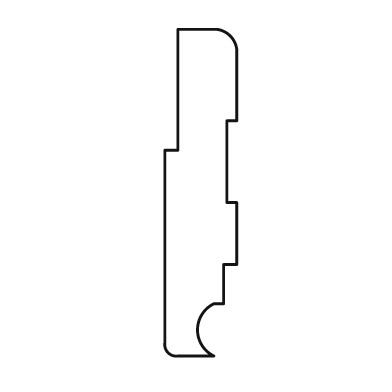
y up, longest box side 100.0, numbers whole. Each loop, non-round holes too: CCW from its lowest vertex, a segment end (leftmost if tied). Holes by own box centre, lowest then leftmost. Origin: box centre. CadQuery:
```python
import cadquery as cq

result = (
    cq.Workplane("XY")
    .moveTo(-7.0, -50.0)
    .lineTo(4.0, -50.0)
    .threePointArc((-1.0, -42.0), (4.0, -34.0))
    .lineTo(7.0, -34.0)
    .lineTo(7.0, -22.0)
    .lineTo(11.0, -22.0)
    .lineTo(11.0, -3.0)
    .lineTo(8.0, -3.0)
    .lineTo(8.0, 22.0)
    .lineTo(11.0, 22.0)
    .lineTo(11.0, 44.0)
    .threePointArc((9.0, 48.0), (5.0, 50.0))
    .lineTo(-7.0, 50.0)
    .lineTo(-7.0, 13.0)
    .lineTo(-11.0, 13.0)
    .lineTo(-11.0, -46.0)
    .threePointArc((-10.0, -49.0), (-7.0, -50.0))
    .close()
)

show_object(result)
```